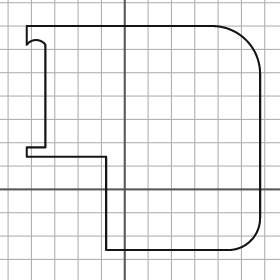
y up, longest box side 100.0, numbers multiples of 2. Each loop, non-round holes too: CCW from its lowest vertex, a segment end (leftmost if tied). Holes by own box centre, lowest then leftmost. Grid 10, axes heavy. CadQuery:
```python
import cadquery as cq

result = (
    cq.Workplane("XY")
    .moveTo(-8.0, -26.0)
    .lineTo(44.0, -26.0)
    .threePointArc((54.0, -22.0), (58.0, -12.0))
    .lineTo(58.0, 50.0)
    .threePointArc((52.0, 64.0), (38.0, 70.0))
    .lineTo(-42.0, 70.0)
    .lineTo(-42.0, 62.0)
    .threePointArc((-38.0, 64.0), (-34.0, 62.0))
    .lineTo(-34.0, 18.0)
    .lineTo(-42.0, 18.0)
    .lineTo(-42.0, 14.0)
    .lineTo(-8.0, 14.0)
    .close()
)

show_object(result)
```